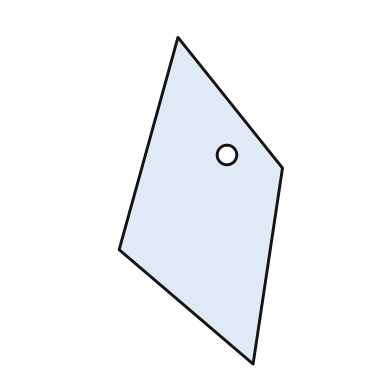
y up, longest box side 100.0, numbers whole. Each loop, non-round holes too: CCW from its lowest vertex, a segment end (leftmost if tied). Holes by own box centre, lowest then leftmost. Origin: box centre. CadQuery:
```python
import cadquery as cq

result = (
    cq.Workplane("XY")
    .moveTo(16.0, -50.0)
    .lineTo(25.0, 10.0)
    .lineTo(-7.0, 50.0)
    .lineTo(-25.0, -15.0)
    .close()
    .moveTo(8.0, 14.0)
    .circle(3.0)
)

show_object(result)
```